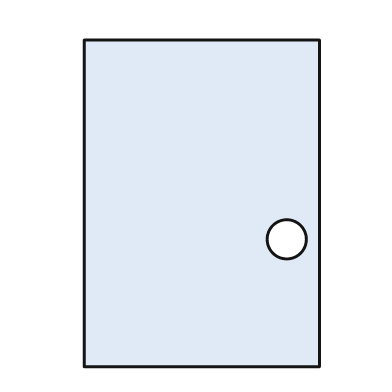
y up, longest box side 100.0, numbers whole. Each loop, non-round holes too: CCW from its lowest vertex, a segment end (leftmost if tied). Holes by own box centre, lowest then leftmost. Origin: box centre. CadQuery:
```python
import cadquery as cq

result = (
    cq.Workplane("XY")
    .moveTo(-36.0, -50.0)
    .lineTo(36.0, -50.0)
    .lineTo(36.0, 50.0)
    .lineTo(-36.0, 50.0)
    .close()
    .moveTo(26.0, -11.0)
    .circle(6.0)
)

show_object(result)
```